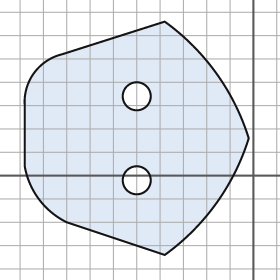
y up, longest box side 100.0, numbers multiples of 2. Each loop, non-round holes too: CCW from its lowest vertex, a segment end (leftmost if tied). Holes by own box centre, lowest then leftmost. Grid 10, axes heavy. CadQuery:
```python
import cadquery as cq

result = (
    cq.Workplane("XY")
    .moveTo(-38.0, -34.0)
    .threePointArc((-16.0, -12.0), (-2.0, 16.0))
    .threePointArc((-16.0, 44.0), (-38.0, 66.0))
    .lineTo(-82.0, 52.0)
    .threePointArc((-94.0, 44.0), (-98.0, 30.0))
    .lineTo(-98.0, 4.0)
    .threePointArc((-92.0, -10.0), (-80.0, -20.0))
    .close()
    .moveTo(-50.0, -2.0)
    .circle(6.0)
    .moveTo(-50.0, 34.0)
    .circle(6.0)
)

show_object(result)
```